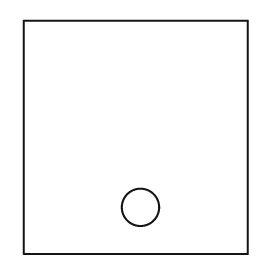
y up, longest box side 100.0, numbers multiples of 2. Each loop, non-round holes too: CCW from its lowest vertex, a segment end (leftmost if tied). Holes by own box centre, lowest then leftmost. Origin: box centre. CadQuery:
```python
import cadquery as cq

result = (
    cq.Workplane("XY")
    .moveTo(-48.0, -50.0)
    .lineTo(48.0, -50.0)
    .lineTo(48.0, 50.0)
    .lineTo(-48.0, 50.0)
    .close()
    .moveTo(2.0, -30.0)
    .circle(8.0)
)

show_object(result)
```